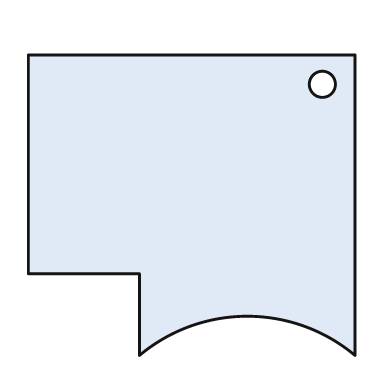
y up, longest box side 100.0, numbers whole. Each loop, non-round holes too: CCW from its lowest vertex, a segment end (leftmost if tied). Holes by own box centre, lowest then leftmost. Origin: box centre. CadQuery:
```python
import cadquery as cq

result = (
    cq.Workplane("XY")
    .moveTo(-16.0, -46.0)
    .threePointArc((17.0, -34.0), (50.0, -46.0))
    .lineTo(50.0, 46.0)
    .lineTo(-50.0, 46.0)
    .lineTo(-50.0, -21.0)
    .lineTo(-16.0, -21.0)
    .close()
    .moveTo(40.0, 37.0)
    .circle(4.0)
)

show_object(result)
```